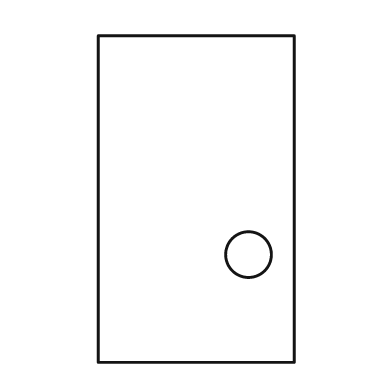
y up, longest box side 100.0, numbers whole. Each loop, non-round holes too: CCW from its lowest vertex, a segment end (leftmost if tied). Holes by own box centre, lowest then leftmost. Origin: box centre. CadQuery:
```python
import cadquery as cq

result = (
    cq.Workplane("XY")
    .moveTo(-30.0, -50.0)
    .lineTo(30.0, -50.0)
    .lineTo(30.0, 50.0)
    .lineTo(-30.0, 50.0)
    .close()
    .moveTo(16.0, -17.0)
    .circle(7.0)
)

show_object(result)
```